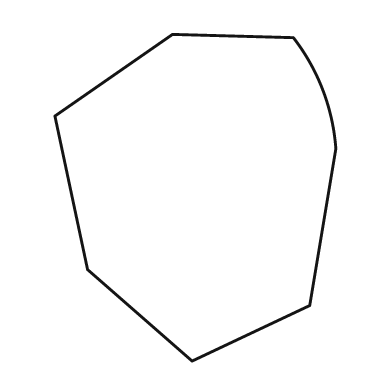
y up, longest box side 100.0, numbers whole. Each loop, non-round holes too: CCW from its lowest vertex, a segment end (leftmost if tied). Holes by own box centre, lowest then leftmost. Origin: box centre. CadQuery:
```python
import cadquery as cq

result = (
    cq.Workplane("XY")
    .moveTo(-1.0, -50.0)
    .lineTo(35.0, -33.0)
    .lineTo(43.0, 15.0)
    .threePointArc((39.0, 33.0), (30.0, 49.0))
    .lineTo(-7.0, 50.0)
    .lineTo(-43.0, 25.0)
    .lineTo(-33.0, -22.0)
    .close()
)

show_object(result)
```